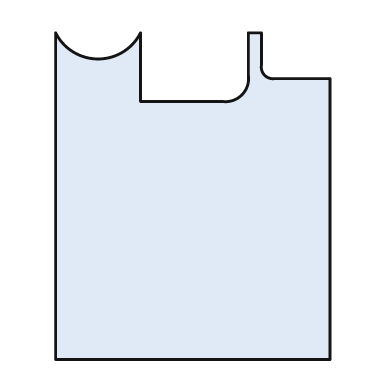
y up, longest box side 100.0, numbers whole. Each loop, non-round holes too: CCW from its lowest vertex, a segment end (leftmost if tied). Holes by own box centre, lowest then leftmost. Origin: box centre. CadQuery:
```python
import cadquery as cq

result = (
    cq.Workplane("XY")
    .moveTo(-42.0, -50.0)
    .lineTo(42.0, -50.0)
    .lineTo(42.0, 36.0)
    .lineTo(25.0, 36.0)
    .threePointArc((22.0, 37.0), (21.0, 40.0))
    .lineTo(21.0, 50.0)
    .lineTo(17.0, 50.0)
    .lineTo(17.0, 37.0)
    .threePointArc((15.0, 31.0), (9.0, 29.0))
    .lineTo(-16.0, 29.0)
    .lineTo(-16.0, 50.0)
    .threePointArc((-29.0, 42.0), (-42.0, 50.0))
    .close()
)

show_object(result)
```